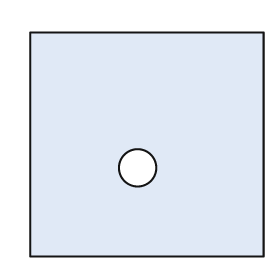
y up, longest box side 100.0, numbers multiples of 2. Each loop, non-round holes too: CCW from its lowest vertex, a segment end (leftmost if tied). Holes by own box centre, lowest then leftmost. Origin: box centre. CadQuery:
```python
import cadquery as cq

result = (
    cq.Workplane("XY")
    .moveTo(-50.0, -48.0)
    .lineTo(50.0, -48.0)
    .lineTo(50.0, 48.0)
    .lineTo(-50.0, 48.0)
    .close()
    .moveTo(-4.0, -10.0)
    .circle(8.0)
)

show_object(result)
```